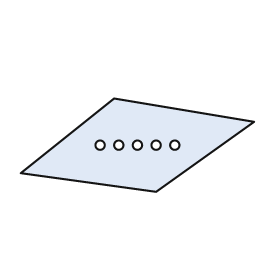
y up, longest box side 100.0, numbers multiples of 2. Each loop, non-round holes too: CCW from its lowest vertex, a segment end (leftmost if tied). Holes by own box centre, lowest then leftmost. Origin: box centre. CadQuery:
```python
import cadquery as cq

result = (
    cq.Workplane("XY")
    .moveTo(8.0, -20.0)
    .lineTo(50.0, 10.0)
    .lineTo(-10.0, 20.0)
    .lineTo(-50.0, -12.0)
    .close()
    .moveTo(-16.0, 0.0)
    .circle(2.0)
    .moveTo(-8.0, 0.0)
    .circle(2.0)
    .moveTo(0.0, 0.0)
    .circle(2.0)
    .moveTo(8.0, 0.0)
    .circle(2.0)
    .moveTo(16.0, 0.0)
    .circle(2.0)
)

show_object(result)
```